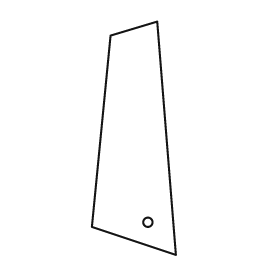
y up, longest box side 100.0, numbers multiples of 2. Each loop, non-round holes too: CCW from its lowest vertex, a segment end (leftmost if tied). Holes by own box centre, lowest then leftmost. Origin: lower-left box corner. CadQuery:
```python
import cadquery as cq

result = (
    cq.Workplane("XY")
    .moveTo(36.0, 0.0)
    .lineTo(28.0, 100.0)
    .lineTo(8.0, 94.0)
    .lineTo(0.0, 12.0)
    .close()
    .moveTo(24.0, 14.0)
    .circle(2.0)
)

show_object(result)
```